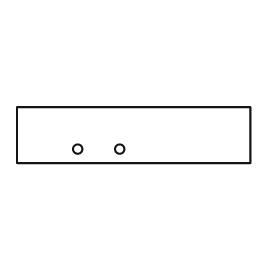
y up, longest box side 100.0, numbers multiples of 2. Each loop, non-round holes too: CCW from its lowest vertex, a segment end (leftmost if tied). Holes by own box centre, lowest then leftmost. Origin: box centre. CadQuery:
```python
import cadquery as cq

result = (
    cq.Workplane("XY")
    .moveTo(-50.0, -12.0)
    .lineTo(50.0, -12.0)
    .lineTo(50.0, 12.0)
    .lineTo(-50.0, 12.0)
    .close()
    .moveTo(-24.0, -6.0)
    .circle(2.0)
    .moveTo(-6.0, -6.0)
    .circle(2.0)
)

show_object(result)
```